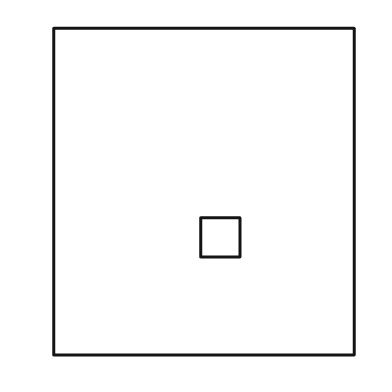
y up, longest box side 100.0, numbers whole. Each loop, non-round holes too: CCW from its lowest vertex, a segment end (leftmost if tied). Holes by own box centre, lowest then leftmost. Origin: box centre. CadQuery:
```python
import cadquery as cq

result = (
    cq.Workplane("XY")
    .moveTo(-46.0, -50.0)
    .lineTo(46.0, -50.0)
    .lineTo(46.0, 50.0)
    .lineTo(-46.0, 50.0)
    .close()
    .moveTo(-1.0, -20.0)
    .lineTo(11.0, -20.0)
    .lineTo(11.0, -8.0)
    .lineTo(-1.0, -8.0)
    .close()
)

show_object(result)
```